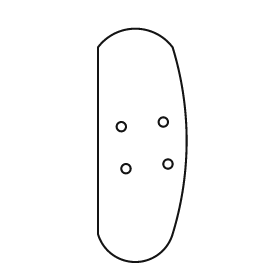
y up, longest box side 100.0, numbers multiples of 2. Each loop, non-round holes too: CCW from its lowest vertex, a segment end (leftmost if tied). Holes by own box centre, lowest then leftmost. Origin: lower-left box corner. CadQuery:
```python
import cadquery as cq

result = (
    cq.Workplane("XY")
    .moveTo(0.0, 12.0)
    .threePointArc((16.0, 0.0), (32.0, 12.0))
    .threePointArc((38.0, 52.0), (32.0, 92.0))
    .threePointArc((16.0, 100.0), (0.0, 92.0))
    .close()
    .moveTo(12.0, 40.0)
    .circle(2.0)
    .moveTo(30.0, 42.0)
    .circle(2.0)
    .moveTo(10.0, 58.0)
    .circle(2.0)
    .moveTo(28.0, 60.0)
    .circle(2.0)
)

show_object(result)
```